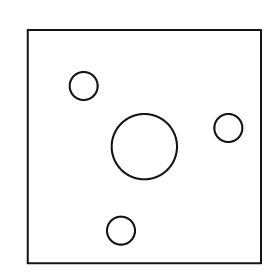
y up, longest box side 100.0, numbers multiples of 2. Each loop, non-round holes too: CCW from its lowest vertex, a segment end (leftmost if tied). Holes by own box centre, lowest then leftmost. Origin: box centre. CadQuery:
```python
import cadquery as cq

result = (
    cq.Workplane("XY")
    .moveTo(-50.0, -50.0)
    .lineTo(50.0, -50.0)
    .lineTo(50.0, 50.0)
    .lineTo(-50.0, 50.0)
    .close()
    .moveTo(-10.0, -36.0)
    .circle(6.0)
    .moveTo(0.0, 0.0)
    .circle(14.0)
    .moveTo(36.0, 8.0)
    .circle(6.0)
    .moveTo(-26.0, 26.0)
    .circle(6.0)
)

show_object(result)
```